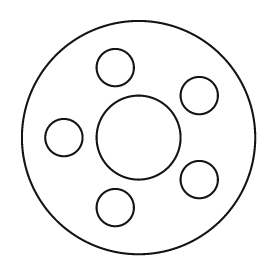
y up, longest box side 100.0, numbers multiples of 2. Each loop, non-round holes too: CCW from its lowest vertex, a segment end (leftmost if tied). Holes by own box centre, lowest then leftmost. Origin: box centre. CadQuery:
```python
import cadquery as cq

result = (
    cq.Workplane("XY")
    .moveTo(0.0, 0.0)
    .circle(50.0)
    .moveTo(-10.0, -30.0)
    .circle(8.0)
    .moveTo(26.0, -18.0)
    .circle(8.0)
    .moveTo(-32.0, 0.0)
    .circle(8.0)
    .moveTo(0.0, 0.0)
    .circle(18.0)
    .moveTo(26.0, 18.0)
    .circle(8.0)
    .moveTo(-10.0, 30.0)
    .circle(8.0)
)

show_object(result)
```